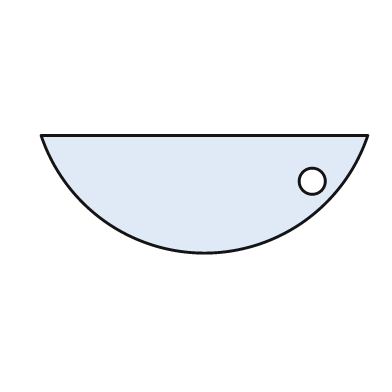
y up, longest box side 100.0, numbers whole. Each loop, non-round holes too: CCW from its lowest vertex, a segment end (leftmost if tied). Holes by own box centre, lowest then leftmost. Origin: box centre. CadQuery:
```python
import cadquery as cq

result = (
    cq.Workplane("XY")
    .moveTo(-50.0, 18.0)
    .threePointArc((0.0, -18.0), (50.0, 18.0))
    .close()
    .moveTo(33.0, 4.0)
    .circle(4.0)
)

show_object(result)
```